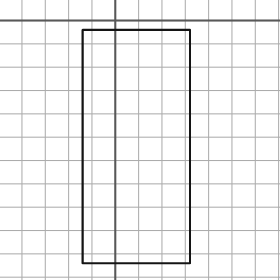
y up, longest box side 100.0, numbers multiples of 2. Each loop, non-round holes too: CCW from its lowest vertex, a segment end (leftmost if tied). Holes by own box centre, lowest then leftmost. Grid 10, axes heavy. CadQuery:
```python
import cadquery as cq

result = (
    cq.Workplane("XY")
    .moveTo(-14.0, -104.0)
    .lineTo(32.0, -104.0)
    .lineTo(32.0, -4.0)
    .lineTo(-14.0, -4.0)
    .close()
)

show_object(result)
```